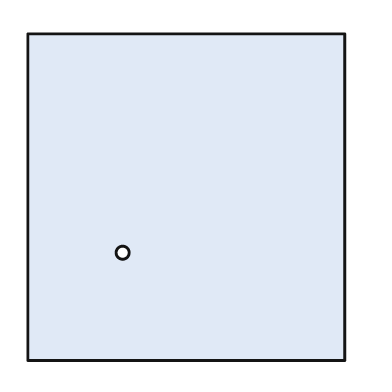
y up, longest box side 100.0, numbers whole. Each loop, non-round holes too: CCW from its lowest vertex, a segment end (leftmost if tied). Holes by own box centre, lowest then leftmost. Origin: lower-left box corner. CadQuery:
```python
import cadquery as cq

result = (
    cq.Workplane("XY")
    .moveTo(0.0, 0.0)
    .lineTo(97.0, 0.0)
    .lineTo(97.0, 100.0)
    .lineTo(0.0, 100.0)
    .close()
    .moveTo(29.0, 33.0)
    .circle(2.0)
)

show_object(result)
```